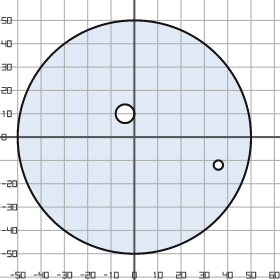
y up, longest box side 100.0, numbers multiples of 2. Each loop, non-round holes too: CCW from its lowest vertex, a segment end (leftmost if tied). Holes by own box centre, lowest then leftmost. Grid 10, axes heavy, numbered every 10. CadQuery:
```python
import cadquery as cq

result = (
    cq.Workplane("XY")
    .moveTo(0.0, 0.0)
    .circle(50.0)
    .moveTo(36.0, -12.0)
    .circle(2.0)
    .moveTo(-4.0, 10.0)
    .circle(4.0)
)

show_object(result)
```